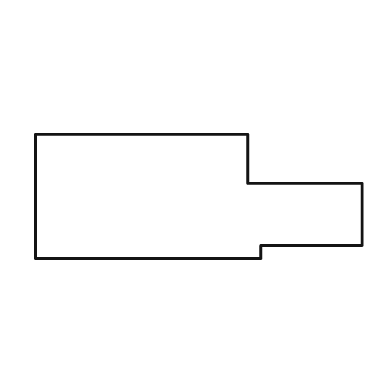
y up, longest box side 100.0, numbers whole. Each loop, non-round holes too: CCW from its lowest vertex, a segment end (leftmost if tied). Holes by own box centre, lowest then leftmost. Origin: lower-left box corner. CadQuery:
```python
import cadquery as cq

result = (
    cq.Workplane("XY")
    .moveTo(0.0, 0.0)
    .lineTo(69.0, 0.0)
    .lineTo(69.0, 4.0)
    .lineTo(100.0, 4.0)
    .lineTo(100.0, 23.0)
    .lineTo(65.0, 23.0)
    .lineTo(65.0, 38.0)
    .lineTo(0.0, 38.0)
    .close()
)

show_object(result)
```